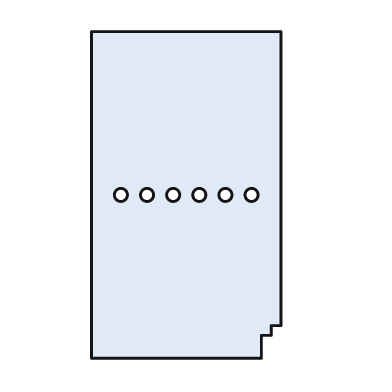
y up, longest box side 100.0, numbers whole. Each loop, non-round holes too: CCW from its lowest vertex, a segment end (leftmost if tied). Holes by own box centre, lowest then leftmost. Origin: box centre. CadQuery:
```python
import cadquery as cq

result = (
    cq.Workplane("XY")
    .moveTo(-29.0, -50.0)
    .lineTo(23.0, -50.0)
    .lineTo(23.0, -43.0)
    .lineTo(26.0, -43.0)
    .lineTo(26.0, -40.0)
    .lineTo(29.0, -40.0)
    .lineTo(29.0, 50.0)
    .lineTo(-29.0, 50.0)
    .close()
    .moveTo(-20.0, 0.0)
    .circle(2.0)
    .moveTo(-12.0, 0.0)
    .circle(2.0)
    .moveTo(-4.0, 0.0)
    .circle(2.0)
    .moveTo(4.0, 0.0)
    .circle(2.0)
    .moveTo(12.0, 0.0)
    .circle(2.0)
    .moveTo(20.0, 0.0)
    .circle(2.0)
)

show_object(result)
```